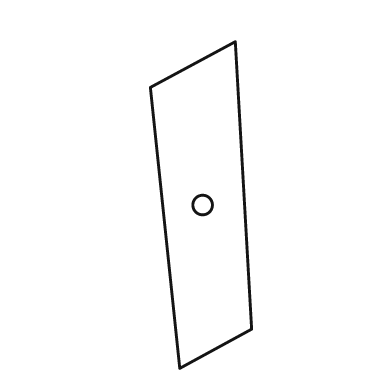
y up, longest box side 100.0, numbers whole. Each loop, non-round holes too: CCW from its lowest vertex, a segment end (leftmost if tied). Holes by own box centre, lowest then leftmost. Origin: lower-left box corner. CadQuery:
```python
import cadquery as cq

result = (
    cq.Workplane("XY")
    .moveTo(9.0, 0.0)
    .lineTo(31.0, 12.0)
    .lineTo(26.0, 100.0)
    .lineTo(0.0, 86.0)
    .close()
    .moveTo(16.0, 50.0)
    .circle(3.0)
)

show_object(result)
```